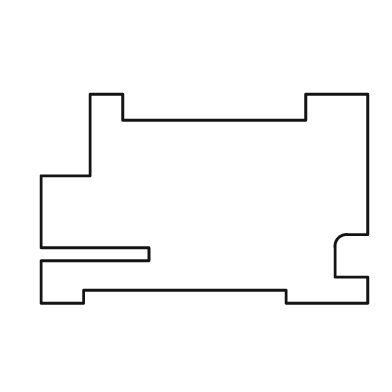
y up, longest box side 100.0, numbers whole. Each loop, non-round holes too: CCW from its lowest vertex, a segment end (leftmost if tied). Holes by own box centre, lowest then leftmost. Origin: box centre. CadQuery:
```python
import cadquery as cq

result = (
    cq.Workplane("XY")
    .moveTo(-50.0, -32.0)
    .lineTo(-37.0, -32.0)
    .lineTo(-37.0, -28.0)
    .lineTo(25.0, -28.0)
    .lineTo(25.0, -32.0)
    .lineTo(50.0, -32.0)
    .lineTo(50.0, -24.0)
    .lineTo(40.0, -24.0)
    .lineTo(40.0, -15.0)
    .threePointArc((41.0, -12.0), (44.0, -11.0))
    .lineTo(50.0, -11.0)
    .lineTo(50.0, 32.0)
    .lineTo(31.0, 32.0)
    .lineTo(31.0, 24.0)
    .lineTo(-25.0, 24.0)
    .lineTo(-25.0, 32.0)
    .lineTo(-35.0, 32.0)
    .lineTo(-35.0, 7.0)
    .lineTo(-50.0, 7.0)
    .lineTo(-50.0, -15.0)
    .lineTo(-17.0, -15.0)
    .lineTo(-17.0, -19.0)
    .lineTo(-50.0, -19.0)
    .close()
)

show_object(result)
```